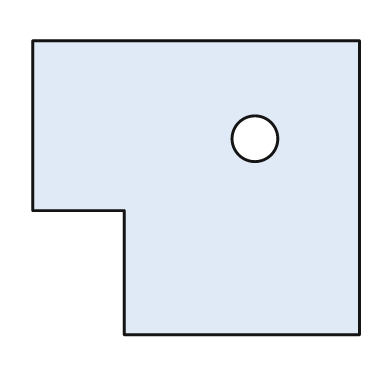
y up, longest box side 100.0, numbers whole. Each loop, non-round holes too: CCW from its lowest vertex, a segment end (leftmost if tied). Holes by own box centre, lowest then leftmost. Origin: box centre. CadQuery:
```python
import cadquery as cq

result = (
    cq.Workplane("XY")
    .moveTo(-22.0, -45.0)
    .lineTo(50.0, -45.0)
    .lineTo(50.0, 45.0)
    .lineTo(-50.0, 45.0)
    .lineTo(-50.0, -7.0)
    .lineTo(-22.0, -7.0)
    .close()
    .moveTo(18.0, 15.0)
    .circle(7.0)
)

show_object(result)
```